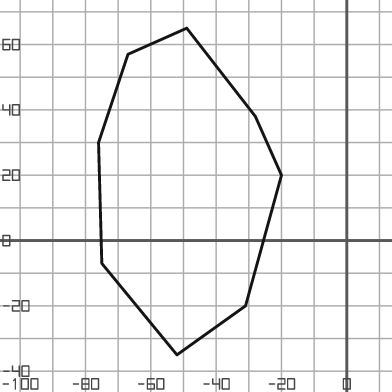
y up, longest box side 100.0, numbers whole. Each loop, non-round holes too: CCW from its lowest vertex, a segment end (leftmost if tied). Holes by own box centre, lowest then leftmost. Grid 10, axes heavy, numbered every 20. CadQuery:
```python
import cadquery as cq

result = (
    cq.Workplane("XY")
    .moveTo(-52.0, -35.0)
    .lineTo(-31.0, -20.0)
    .lineTo(-20.0, 20.0)
    .lineTo(-28.0, 38.0)
    .lineTo(-49.0, 65.0)
    .lineTo(-67.0, 57.0)
    .lineTo(-76.0, 30.0)
    .lineTo(-75.0, -7.0)
    .close()
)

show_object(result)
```